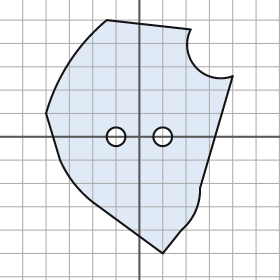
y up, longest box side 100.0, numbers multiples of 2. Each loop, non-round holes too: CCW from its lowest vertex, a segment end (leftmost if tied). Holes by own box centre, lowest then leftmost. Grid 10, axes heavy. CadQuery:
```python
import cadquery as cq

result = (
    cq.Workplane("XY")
    .moveTo(10.0, -50.0)
    .lineTo(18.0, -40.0)
    .threePointArc((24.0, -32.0), (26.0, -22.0))
    .lineTo(40.0, 26.0)
    .threePointArc((24.0, 30.0), (22.0, 46.0))
    .lineTo(-14.0, 50.0)
    .threePointArc((-30.0, 32.0), (-40.0, 10.0))
    .lineTo(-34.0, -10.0)
    .threePointArc((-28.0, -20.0), (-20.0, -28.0))
    .close()
    .moveTo(-10.0, 0.0)
    .circle(4.0)
    .moveTo(10.0, 0.0)
    .circle(4.0)
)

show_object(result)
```